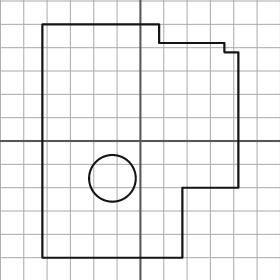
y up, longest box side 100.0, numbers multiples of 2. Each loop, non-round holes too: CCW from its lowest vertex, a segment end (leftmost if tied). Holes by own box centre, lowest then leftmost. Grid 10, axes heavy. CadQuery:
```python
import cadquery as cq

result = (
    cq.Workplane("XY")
    .moveTo(-42.0, -50.0)
    .lineTo(18.0, -50.0)
    .lineTo(18.0, -20.0)
    .lineTo(42.0, -20.0)
    .lineTo(42.0, 38.0)
    .lineTo(36.0, 38.0)
    .lineTo(36.0, 42.0)
    .lineTo(8.0, 42.0)
    .lineTo(8.0, 50.0)
    .lineTo(-42.0, 50.0)
    .close()
    .moveTo(-12.0, -16.0)
    .circle(10.0)
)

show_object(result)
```